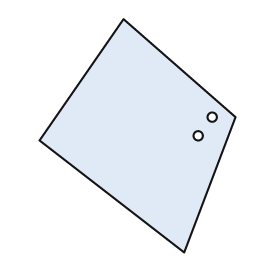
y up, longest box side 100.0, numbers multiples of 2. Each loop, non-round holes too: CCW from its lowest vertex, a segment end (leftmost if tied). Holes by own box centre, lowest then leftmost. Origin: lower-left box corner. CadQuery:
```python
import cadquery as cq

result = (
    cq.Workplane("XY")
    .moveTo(62.0, 0.0)
    .lineTo(84.0, 58.0)
    .lineTo(36.0, 100.0)
    .lineTo(0.0, 48.0)
    .close()
    .moveTo(68.0, 50.0)
    .circle(2.0)
    .moveTo(74.0, 58.0)
    .circle(2.0)
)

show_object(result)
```